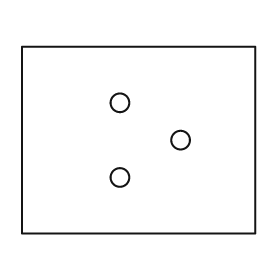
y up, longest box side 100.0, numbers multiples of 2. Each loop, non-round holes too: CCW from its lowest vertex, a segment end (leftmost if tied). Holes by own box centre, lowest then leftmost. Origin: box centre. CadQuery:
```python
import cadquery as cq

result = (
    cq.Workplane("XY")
    .moveTo(-50.0, -40.0)
    .lineTo(50.0, -40.0)
    .lineTo(50.0, 40.0)
    .lineTo(-50.0, 40.0)
    .close()
    .moveTo(-8.0, -16.0)
    .circle(4.0)
    .moveTo(18.0, 0.0)
    .circle(4.0)
    .moveTo(-8.0, 16.0)
    .circle(4.0)
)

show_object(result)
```